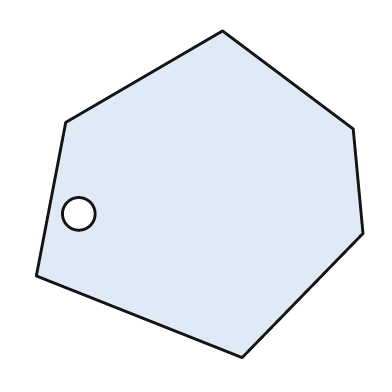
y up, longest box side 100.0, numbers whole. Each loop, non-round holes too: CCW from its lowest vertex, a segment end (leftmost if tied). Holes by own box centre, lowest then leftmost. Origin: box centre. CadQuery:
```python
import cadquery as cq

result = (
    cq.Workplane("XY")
    .moveTo(13.0, -50.0)
    .lineTo(50.0, -12.0)
    .lineTo(47.0, 20.0)
    .lineTo(7.0, 50.0)
    .lineTo(-41.0, 22.0)
    .lineTo(-50.0, -25.0)
    .close()
    .moveTo(-37.0, -6.0)
    .circle(5.0)
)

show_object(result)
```